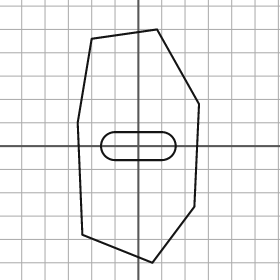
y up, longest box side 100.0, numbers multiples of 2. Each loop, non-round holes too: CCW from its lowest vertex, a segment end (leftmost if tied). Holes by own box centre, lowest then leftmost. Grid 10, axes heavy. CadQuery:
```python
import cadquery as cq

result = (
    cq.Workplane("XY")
    .moveTo(6.0, -50.0)
    .lineTo(24.0, -26.0)
    .lineTo(26.0, 18.0)
    .lineTo(8.0, 50.0)
    .lineTo(-20.0, 46.0)
    .lineTo(-26.0, 10.0)
    .lineTo(-24.0, -38.0)
    .close()
    .moveTo(-10.0, -6.0)
    .lineTo(10.0, -6.0)
    .threePointArc((16.0, 0.0), (10.0, 6.0))
    .lineTo(-10.0, 6.0)
    .threePointArc((-16.0, 0.0), (-10.0, -6.0))
    .close()
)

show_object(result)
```